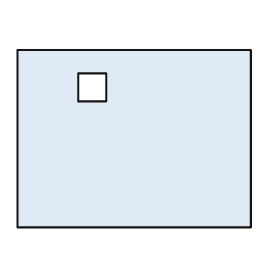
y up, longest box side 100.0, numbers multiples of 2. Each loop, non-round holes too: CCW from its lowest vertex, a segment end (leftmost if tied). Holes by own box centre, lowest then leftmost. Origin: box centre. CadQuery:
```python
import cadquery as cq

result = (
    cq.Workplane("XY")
    .moveTo(-50.0, -38.0)
    .lineTo(50.0, -38.0)
    .lineTo(50.0, 38.0)
    .lineTo(-50.0, 38.0)
    .close()
    .moveTo(-24.0, 16.0)
    .lineTo(-12.0, 16.0)
    .lineTo(-12.0, 28.0)
    .lineTo(-24.0, 28.0)
    .close()
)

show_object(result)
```